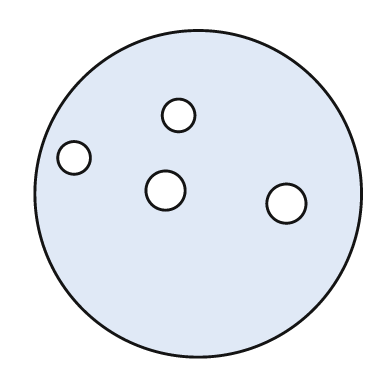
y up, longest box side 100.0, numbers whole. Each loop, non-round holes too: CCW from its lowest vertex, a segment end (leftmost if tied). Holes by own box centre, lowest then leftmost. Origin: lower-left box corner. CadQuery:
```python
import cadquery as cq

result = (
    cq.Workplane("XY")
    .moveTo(50.0, 50.0)
    .circle(50.0)
    .moveTo(77.0, 47.0)
    .circle(6.0)
    .moveTo(40.0, 51.0)
    .circle(6.0)
    .moveTo(12.0, 61.0)
    .circle(5.0)
    .moveTo(44.0, 74.0)
    .circle(5.0)
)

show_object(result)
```